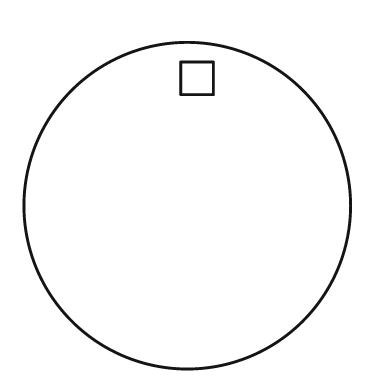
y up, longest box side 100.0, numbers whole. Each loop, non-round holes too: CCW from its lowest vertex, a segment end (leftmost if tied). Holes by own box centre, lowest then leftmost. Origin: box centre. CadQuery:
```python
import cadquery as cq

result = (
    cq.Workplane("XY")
    .moveTo(0.0, 0.0)
    .circle(50.0)
    .moveTo(-2.0, 34.0)
    .lineTo(8.0, 34.0)
    .lineTo(8.0, 44.0)
    .lineTo(-2.0, 44.0)
    .close()
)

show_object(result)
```